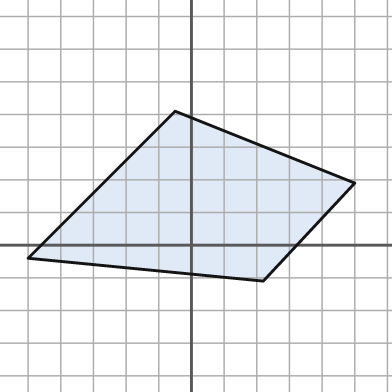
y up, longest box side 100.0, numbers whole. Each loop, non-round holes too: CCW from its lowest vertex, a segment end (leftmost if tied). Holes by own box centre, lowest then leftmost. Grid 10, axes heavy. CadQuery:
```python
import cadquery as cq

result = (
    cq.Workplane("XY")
    .moveTo(22.0, -11.0)
    .lineTo(50.0, 19.0)
    .lineTo(-5.0, 41.0)
    .lineTo(-50.0, -4.0)
    .close()
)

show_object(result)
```